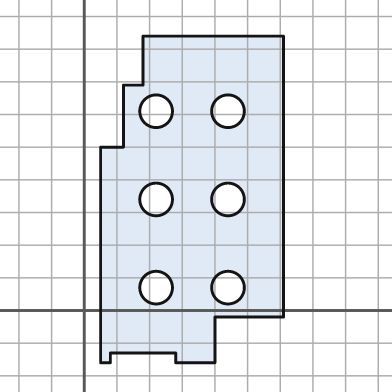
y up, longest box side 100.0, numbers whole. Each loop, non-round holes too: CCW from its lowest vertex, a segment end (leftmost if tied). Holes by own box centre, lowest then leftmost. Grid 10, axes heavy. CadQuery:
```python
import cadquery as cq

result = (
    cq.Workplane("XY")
    .moveTo(5.0, -16.0)
    .lineTo(8.0, -16.0)
    .lineTo(8.0, -13.0)
    .lineTo(28.0, -13.0)
    .lineTo(28.0, -16.0)
    .lineTo(40.0, -16.0)
    .lineTo(40.0, -2.0)
    .lineTo(61.0, -2.0)
    .lineTo(61.0, 84.0)
    .lineTo(18.0, 84.0)
    .lineTo(18.0, 69.0)
    .lineTo(12.0, 69.0)
    .lineTo(12.0, 50.0)
    .lineTo(5.0, 50.0)
    .close()
    .moveTo(22.0, 7.0)
    .circle(5.0)
    .moveTo(44.0, 7.0)
    .circle(5.0)
    .moveTo(22.0, 34.0)
    .circle(5.0)
    .moveTo(44.0, 34.0)
    .circle(5.0)
    .moveTo(22.0, 61.0)
    .circle(5.0)
    .moveTo(44.0, 61.0)
    .circle(5.0)
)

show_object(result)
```